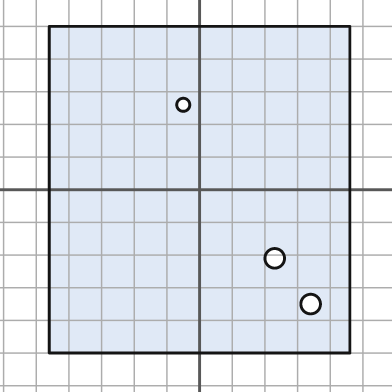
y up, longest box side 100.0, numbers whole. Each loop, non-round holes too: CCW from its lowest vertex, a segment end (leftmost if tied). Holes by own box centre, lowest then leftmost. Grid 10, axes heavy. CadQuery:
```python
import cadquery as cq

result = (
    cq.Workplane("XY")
    .moveTo(-46.0, -50.0)
    .lineTo(46.0, -50.0)
    .lineTo(46.0, 50.0)
    .lineTo(-46.0, 50.0)
    .close()
    .moveTo(34.0, -35.0)
    .circle(3.0)
    .moveTo(23.0, -21.0)
    .circle(3.0)
    .moveTo(-5.0, 26.0)
    .circle(2.0)
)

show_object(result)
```